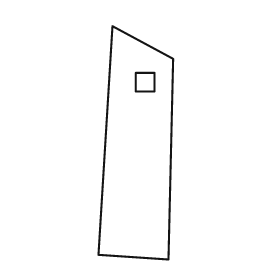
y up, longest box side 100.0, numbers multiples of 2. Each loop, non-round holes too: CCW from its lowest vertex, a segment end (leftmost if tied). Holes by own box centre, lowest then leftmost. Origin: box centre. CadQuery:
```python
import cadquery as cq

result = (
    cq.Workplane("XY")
    .moveTo(14.0, -50.0)
    .lineTo(16.0, 36.0)
    .lineTo(-10.0, 50.0)
    .lineTo(-16.0, -48.0)
    .close()
    .moveTo(0.0, 22.0)
    .lineTo(8.0, 22.0)
    .lineTo(8.0, 30.0)
    .lineTo(0.0, 30.0)
    .close()
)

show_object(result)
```